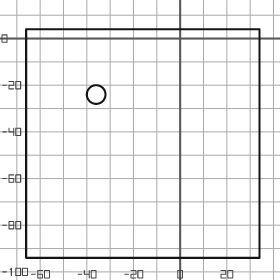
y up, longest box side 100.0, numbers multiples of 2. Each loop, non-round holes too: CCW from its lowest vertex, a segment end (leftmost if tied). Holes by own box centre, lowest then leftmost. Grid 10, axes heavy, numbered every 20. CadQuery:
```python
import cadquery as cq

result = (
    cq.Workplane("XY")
    .moveTo(-66.0, -94.0)
    .lineTo(34.0, -94.0)
    .lineTo(34.0, 4.0)
    .lineTo(-66.0, 4.0)
    .close()
    .moveTo(-36.0, -24.0)
    .circle(4.0)
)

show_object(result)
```